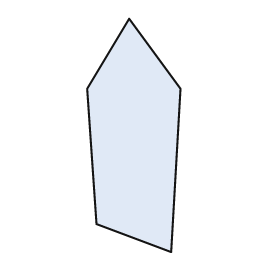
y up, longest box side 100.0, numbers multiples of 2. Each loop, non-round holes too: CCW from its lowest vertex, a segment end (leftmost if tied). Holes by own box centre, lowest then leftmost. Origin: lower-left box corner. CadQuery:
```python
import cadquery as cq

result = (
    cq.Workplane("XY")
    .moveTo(36.0, 0.0)
    .lineTo(40.0, 70.0)
    .lineTo(18.0, 100.0)
    .lineTo(0.0, 70.0)
    .lineTo(4.0, 12.0)
    .close()
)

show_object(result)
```